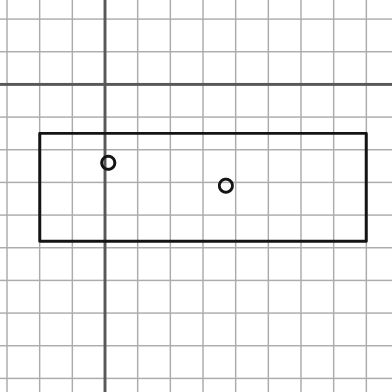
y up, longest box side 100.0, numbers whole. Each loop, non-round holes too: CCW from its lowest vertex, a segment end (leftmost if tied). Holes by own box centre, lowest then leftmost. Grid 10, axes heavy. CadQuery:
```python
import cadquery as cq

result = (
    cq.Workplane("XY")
    .moveTo(-20.0, -48.0)
    .lineTo(80.0, -48.0)
    .lineTo(80.0, -15.0)
    .lineTo(-20.0, -15.0)
    .close()
    .moveTo(37.0, -31.0)
    .circle(2.0)
    .moveTo(1.0, -24.0)
    .circle(2.0)
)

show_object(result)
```